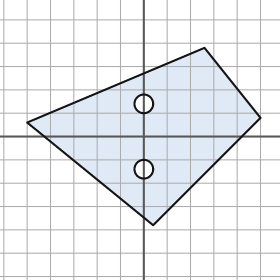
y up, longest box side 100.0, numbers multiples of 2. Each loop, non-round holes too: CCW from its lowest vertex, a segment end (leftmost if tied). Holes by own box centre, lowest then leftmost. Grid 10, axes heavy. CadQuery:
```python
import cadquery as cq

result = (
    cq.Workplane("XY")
    .moveTo(4.0, -38.0)
    .lineTo(50.0, 8.0)
    .lineTo(26.0, 38.0)
    .lineTo(-50.0, 6.0)
    .close()
    .moveTo(0.0, -14.0)
    .circle(4.0)
    .moveTo(0.0, 14.0)
    .circle(4.0)
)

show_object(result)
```